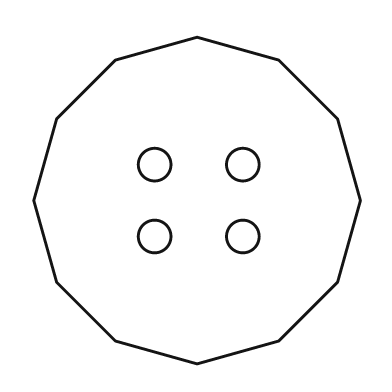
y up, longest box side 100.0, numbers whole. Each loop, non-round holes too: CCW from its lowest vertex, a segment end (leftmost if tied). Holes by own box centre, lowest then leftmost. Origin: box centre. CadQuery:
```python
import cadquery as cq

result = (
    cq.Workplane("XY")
    .moveTo(0.0, -50.0)
    .lineTo(25.0, -43.0)
    .lineTo(43.0, -25.0)
    .lineTo(50.0, 0.0)
    .lineTo(43.0, 25.0)
    .lineTo(25.0, 43.0)
    .lineTo(0.0, 50.0)
    .lineTo(-25.0, 43.0)
    .lineTo(-43.0, 25.0)
    .lineTo(-50.0, 0.0)
    .lineTo(-43.0, -25.0)
    .lineTo(-25.0, -43.0)
    .close()
    .moveTo(-13.0, -11.0)
    .circle(5.0)
    .moveTo(14.0, -11.0)
    .circle(5.0)
    .moveTo(-13.0, 11.0)
    .circle(5.0)
    .moveTo(14.0, 11.0)
    .circle(5.0)
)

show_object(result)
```